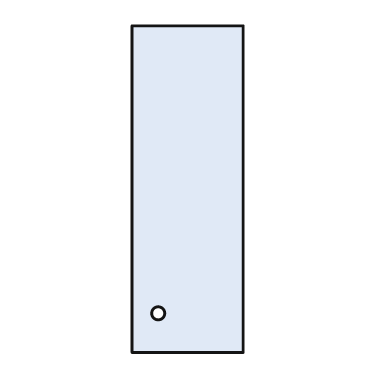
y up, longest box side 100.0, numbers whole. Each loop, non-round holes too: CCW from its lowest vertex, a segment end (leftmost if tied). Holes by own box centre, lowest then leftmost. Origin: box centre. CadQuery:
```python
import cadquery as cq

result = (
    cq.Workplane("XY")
    .moveTo(-17.0, -50.0)
    .lineTo(17.0, -50.0)
    .lineTo(17.0, 50.0)
    .lineTo(-17.0, 50.0)
    .close()
    .moveTo(-9.0, -38.0)
    .circle(2.0)
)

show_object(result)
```